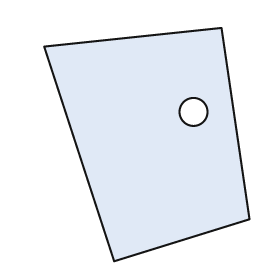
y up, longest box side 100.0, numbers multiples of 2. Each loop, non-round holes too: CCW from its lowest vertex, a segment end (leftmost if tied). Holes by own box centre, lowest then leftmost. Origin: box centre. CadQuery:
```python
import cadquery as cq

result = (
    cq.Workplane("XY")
    .moveTo(-14.0, -50.0)
    .lineTo(44.0, -32.0)
    .lineTo(32.0, 50.0)
    .lineTo(-44.0, 42.0)
    .close()
    .moveTo(20.0, 14.0)
    .circle(6.0)
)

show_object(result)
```